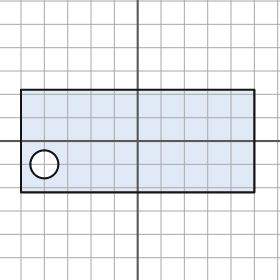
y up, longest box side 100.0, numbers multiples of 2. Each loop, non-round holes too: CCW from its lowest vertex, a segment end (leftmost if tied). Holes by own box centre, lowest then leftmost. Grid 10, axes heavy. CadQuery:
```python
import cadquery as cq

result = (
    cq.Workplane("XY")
    .moveTo(-50.0, -22.0)
    .lineTo(50.0, -22.0)
    .lineTo(50.0, 22.0)
    .lineTo(-50.0, 22.0)
    .close()
    .moveTo(-40.0, -10.0)
    .circle(6.0)
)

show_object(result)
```